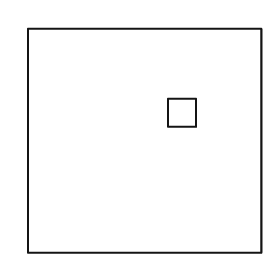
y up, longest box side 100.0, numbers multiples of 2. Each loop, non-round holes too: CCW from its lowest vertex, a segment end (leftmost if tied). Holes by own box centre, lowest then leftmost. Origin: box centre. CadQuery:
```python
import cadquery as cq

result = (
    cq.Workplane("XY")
    .moveTo(-50.0, -48.0)
    .lineTo(50.0, -48.0)
    .lineTo(50.0, 48.0)
    .lineTo(-50.0, 48.0)
    .close()
    .moveTo(10.0, 6.0)
    .lineTo(22.0, 6.0)
    .lineTo(22.0, 18.0)
    .lineTo(10.0, 18.0)
    .close()
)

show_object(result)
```